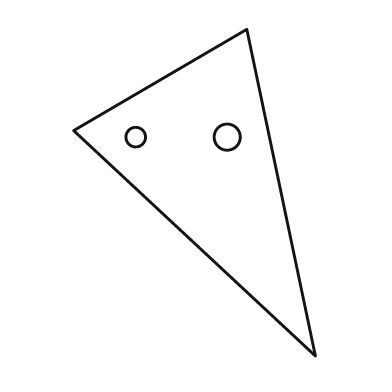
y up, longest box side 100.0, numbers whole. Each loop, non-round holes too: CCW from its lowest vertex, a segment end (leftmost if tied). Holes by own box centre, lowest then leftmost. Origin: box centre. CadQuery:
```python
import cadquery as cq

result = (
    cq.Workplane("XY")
    .moveTo(37.0, -50.0)
    .lineTo(16.0, 50.0)
    .lineTo(-37.0, 19.0)
    .close()
    .moveTo(-18.0, 17.0)
    .circle(3.0)
    .moveTo(10.0, 17.0)
    .circle(4.0)
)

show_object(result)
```